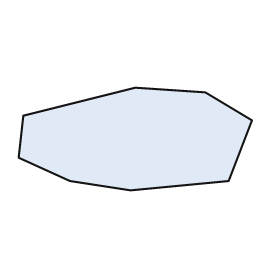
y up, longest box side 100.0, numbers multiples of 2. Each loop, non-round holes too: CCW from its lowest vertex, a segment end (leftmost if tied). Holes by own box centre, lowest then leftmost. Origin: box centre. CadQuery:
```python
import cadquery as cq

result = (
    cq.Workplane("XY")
    .moveTo(-2.0, -22.0)
    .lineTo(40.0, -18.0)
    .lineTo(50.0, 8.0)
    .lineTo(30.0, 20.0)
    .lineTo(0.0, 22.0)
    .lineTo(-48.0, 10.0)
    .lineTo(-50.0, -8.0)
    .lineTo(-28.0, -18.0)
    .close()
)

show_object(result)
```